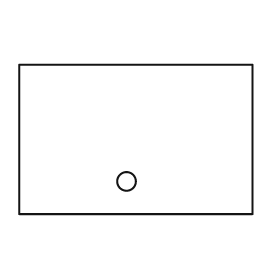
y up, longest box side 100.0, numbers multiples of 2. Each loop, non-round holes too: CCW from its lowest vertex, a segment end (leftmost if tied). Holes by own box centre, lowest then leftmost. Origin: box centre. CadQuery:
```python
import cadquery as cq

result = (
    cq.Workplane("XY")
    .moveTo(-50.0, -32.0)
    .lineTo(50.0, -32.0)
    .lineTo(50.0, 32.0)
    .lineTo(-50.0, 32.0)
    .close()
    .moveTo(-4.0, -18.0)
    .circle(4.0)
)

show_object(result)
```